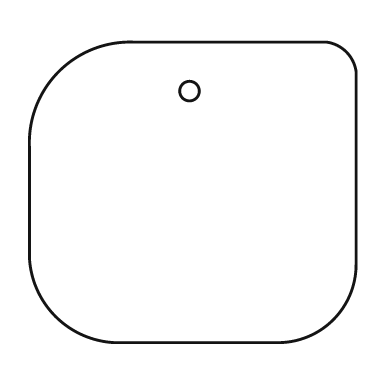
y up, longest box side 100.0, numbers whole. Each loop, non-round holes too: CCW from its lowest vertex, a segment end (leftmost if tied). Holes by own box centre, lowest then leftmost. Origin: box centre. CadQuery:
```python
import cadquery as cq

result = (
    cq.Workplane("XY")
    .moveTo(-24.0, -46.0)
    .lineTo(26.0, -46.0)
    .threePointArc((43.0, -39.0), (50.0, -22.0))
    .lineTo(50.0, 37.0)
    .threePointArc((47.0, 43.0), (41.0, 46.0))
    .lineTo(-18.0, 46.0)
    .threePointArc((-41.0, 37.0), (-50.0, 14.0))
    .lineTo(-50.0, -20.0)
    .threePointArc((-42.0, -38.0), (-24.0, -46.0))
    .close()
    .moveTo(-1.0, 31.0)
    .circle(3.0)
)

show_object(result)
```